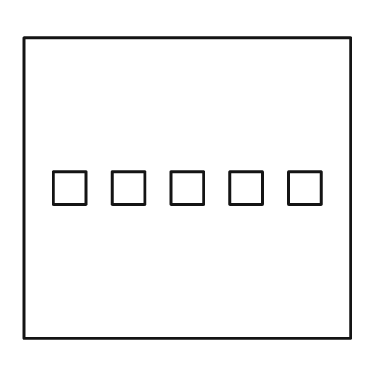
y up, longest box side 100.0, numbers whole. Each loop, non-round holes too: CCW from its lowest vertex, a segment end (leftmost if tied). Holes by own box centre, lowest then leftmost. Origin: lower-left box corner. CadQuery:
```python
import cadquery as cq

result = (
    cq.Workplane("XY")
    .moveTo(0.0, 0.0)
    .lineTo(100.0, 0.0)
    .lineTo(100.0, 92.0)
    .lineTo(0.0, 92.0)
    .close()
    .moveTo(9.0, 41.0)
    .lineTo(19.0, 41.0)
    .lineTo(19.0, 51.0)
    .lineTo(9.0, 51.0)
    .close()
    .moveTo(27.0, 41.0)
    .lineTo(37.0, 41.0)
    .lineTo(37.0, 51.0)
    .lineTo(27.0, 51.0)
    .close()
    .moveTo(45.0, 41.0)
    .lineTo(55.0, 41.0)
    .lineTo(55.0, 51.0)
    .lineTo(45.0, 51.0)
    .close()
    .moveTo(63.0, 41.0)
    .lineTo(73.0, 41.0)
    .lineTo(73.0, 51.0)
    .lineTo(63.0, 51.0)
    .close()
    .moveTo(81.0, 41.0)
    .lineTo(91.0, 41.0)
    .lineTo(91.0, 51.0)
    .lineTo(81.0, 51.0)
    .close()
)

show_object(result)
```